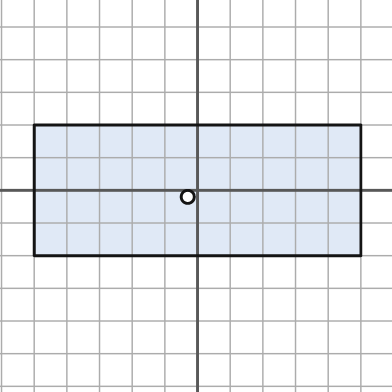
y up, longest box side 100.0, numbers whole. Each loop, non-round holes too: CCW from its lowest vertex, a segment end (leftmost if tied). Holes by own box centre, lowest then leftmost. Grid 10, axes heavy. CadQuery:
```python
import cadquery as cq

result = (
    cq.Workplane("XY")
    .moveTo(-50.0, -20.0)
    .lineTo(50.0, -20.0)
    .lineTo(50.0, 20.0)
    .lineTo(-50.0, 20.0)
    .close()
    .moveTo(-3.0, -2.0)
    .circle(2.0)
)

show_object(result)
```